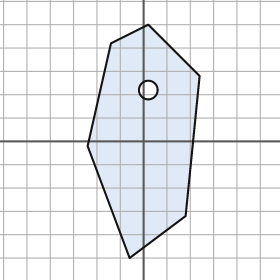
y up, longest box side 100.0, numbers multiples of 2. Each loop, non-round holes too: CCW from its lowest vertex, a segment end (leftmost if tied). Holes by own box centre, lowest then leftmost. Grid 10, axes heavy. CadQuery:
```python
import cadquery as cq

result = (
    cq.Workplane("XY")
    .moveTo(-6.0, -50.0)
    .lineTo(18.0, -32.0)
    .lineTo(24.0, 28.0)
    .lineTo(2.0, 50.0)
    .lineTo(-14.0, 42.0)
    .lineTo(-24.0, -2.0)
    .close()
    .moveTo(2.0, 22.0)
    .circle(4.0)
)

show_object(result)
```